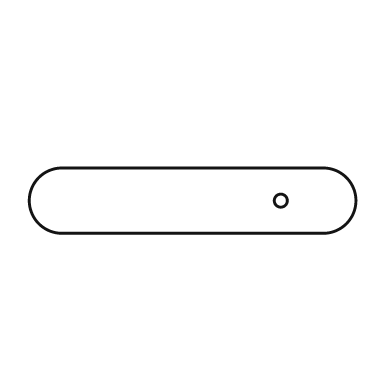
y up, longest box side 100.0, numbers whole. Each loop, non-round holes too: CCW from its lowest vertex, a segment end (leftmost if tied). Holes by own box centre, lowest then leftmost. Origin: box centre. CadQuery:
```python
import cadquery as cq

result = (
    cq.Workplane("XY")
    .moveTo(-40.0, -10.0)
    .lineTo(40.0, -10.0)
    .threePointArc((50.0, 0.0), (40.0, 10.0))
    .lineTo(-40.0, 10.0)
    .threePointArc((-50.0, 0.0), (-40.0, -10.0))
    .close()
    .moveTo(27.0, 0.0)
    .circle(2.0)
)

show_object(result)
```